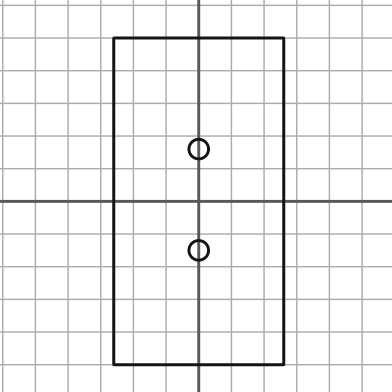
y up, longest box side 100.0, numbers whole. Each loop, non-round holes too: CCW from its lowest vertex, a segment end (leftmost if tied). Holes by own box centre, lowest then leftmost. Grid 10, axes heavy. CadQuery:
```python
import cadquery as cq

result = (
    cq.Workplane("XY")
    .moveTo(-26.0, -50.0)
    .lineTo(26.0, -50.0)
    .lineTo(26.0, 50.0)
    .lineTo(-26.0, 50.0)
    .close()
    .moveTo(0.0, -15.0)
    .circle(3.0)
    .moveTo(0.0, 16.0)
    .circle(3.0)
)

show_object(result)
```